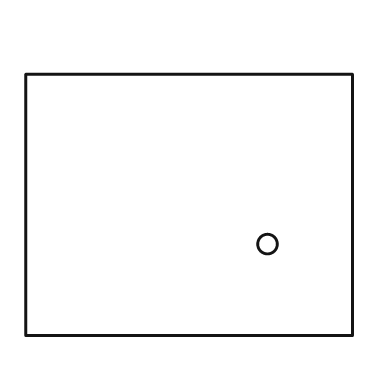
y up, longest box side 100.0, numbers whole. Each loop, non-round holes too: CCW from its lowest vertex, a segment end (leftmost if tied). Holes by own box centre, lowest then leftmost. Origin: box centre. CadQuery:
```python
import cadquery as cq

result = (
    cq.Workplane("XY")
    .moveTo(-50.0, -40.0)
    .lineTo(50.0, -40.0)
    .lineTo(50.0, 40.0)
    .lineTo(-50.0, 40.0)
    .close()
    .moveTo(24.0, -12.0)
    .circle(3.0)
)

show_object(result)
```